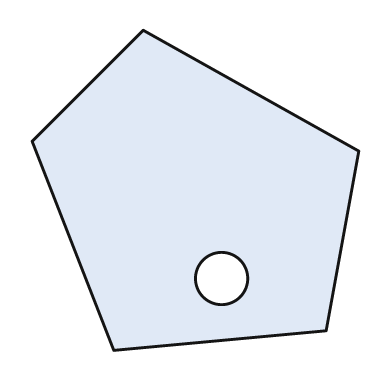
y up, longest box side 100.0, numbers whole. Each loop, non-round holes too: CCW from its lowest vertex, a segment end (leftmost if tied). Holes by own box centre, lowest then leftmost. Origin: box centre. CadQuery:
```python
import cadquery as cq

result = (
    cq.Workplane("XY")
    .moveTo(-25.0, -49.0)
    .lineTo(40.0, -43.0)
    .lineTo(50.0, 12.0)
    .lineTo(-16.0, 49.0)
    .lineTo(-50.0, 15.0)
    .close()
    .moveTo(8.0, -27.0)
    .circle(8.0)
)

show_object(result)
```